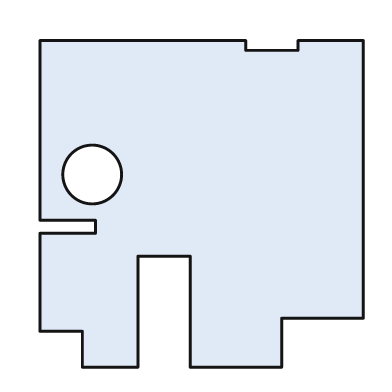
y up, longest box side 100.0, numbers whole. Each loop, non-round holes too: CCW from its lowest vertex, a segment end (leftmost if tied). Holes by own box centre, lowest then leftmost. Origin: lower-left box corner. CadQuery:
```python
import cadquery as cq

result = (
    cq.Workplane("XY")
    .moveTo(13.0, 0.0)
    .lineTo(30.0, 0.0)
    .lineTo(30.0, 34.0)
    .lineTo(46.0, 34.0)
    .lineTo(46.0, 0.0)
    .lineTo(74.0, 0.0)
    .lineTo(74.0, 15.0)
    .lineTo(99.0, 15.0)
    .lineTo(99.0, 100.0)
    .lineTo(79.0, 100.0)
    .lineTo(79.0, 97.0)
    .lineTo(63.0, 97.0)
    .lineTo(63.0, 100.0)
    .lineTo(0.0, 100.0)
    .lineTo(0.0, 45.0)
    .lineTo(17.0, 45.0)
    .lineTo(17.0, 41.0)
    .lineTo(0.0, 41.0)
    .lineTo(0.0, 11.0)
    .lineTo(13.0, 11.0)
    .close()
    .moveTo(16.0, 59.0)
    .circle(9.0)
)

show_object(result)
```